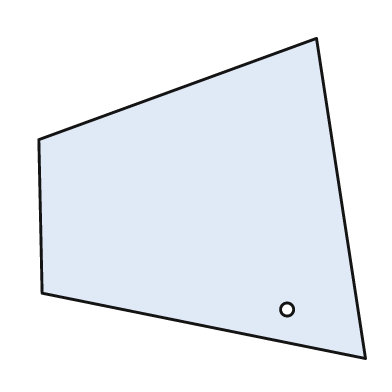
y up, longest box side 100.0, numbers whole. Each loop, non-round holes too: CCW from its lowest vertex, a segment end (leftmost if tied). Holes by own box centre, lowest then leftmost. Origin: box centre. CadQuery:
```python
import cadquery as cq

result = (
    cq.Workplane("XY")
    .moveTo(50.0, -49.0)
    .lineTo(35.0, 49.0)
    .lineTo(-50.0, 18.0)
    .lineTo(-49.0, -29.0)
    .close()
    .moveTo(26.0, -34.0)
    .circle(2.0)
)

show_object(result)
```